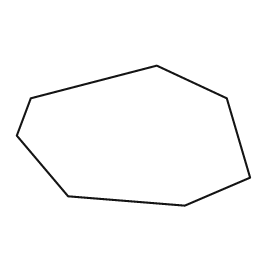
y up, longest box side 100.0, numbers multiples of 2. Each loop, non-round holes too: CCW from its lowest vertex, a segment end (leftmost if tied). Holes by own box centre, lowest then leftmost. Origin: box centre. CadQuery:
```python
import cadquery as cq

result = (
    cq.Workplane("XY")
    .moveTo(22.0, -30.0)
    .lineTo(50.0, -18.0)
    .lineTo(40.0, 16.0)
    .lineTo(10.0, 30.0)
    .lineTo(-44.0, 16.0)
    .lineTo(-50.0, 0.0)
    .lineTo(-28.0, -26.0)
    .close()
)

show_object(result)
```